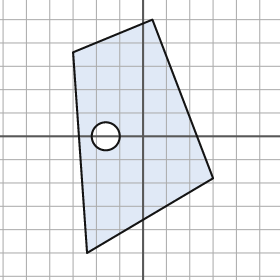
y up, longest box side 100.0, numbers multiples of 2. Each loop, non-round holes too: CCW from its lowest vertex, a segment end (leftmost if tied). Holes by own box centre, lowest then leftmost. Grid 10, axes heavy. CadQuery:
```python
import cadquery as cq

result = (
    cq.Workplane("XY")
    .moveTo(-24.0, -50.0)
    .lineTo(30.0, -18.0)
    .lineTo(4.0, 50.0)
    .lineTo(-30.0, 36.0)
    .close()
    .moveTo(-16.0, 0.0)
    .circle(6.0)
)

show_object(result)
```